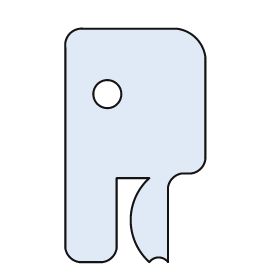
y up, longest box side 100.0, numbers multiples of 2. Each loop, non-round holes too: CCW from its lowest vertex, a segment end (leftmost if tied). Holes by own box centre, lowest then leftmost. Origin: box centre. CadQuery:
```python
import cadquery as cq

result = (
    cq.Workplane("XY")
    .moveTo(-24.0, -50.0)
    .lineTo(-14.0, -50.0)
    .threePointArc((-10.0, -48.0), (-8.0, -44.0))
    .lineTo(-8.0, -14.0)
    .lineTo(6.0, -14.0)
    .threePointArc((-2.0, -32.0), (6.0, -50.0))
    .threePointArc((10.0, -48.0), (14.0, -50.0))
    .lineTo(14.0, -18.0)
    .threePointArc((16.0, -14.0), (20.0, -12.0))
    .lineTo(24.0, -12.0)
    .threePointArc((28.0, -10.0), (30.0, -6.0))
    .lineTo(30.0, 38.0)
    .threePointArc((26.0, 46.0), (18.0, 50.0))
    .lineTo(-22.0, 50.0)
    .threePointArc((-28.0, 48.0), (-30.0, 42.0))
    .lineTo(-30.0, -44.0)
    .threePointArc((-28.0, -48.0), (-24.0, -50.0))
    .close()
    .moveTo(-12.0, 22.0)
    .circle(6.0)
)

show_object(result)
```